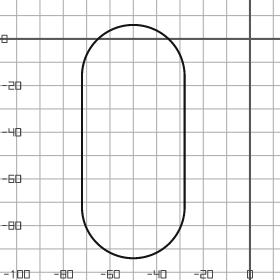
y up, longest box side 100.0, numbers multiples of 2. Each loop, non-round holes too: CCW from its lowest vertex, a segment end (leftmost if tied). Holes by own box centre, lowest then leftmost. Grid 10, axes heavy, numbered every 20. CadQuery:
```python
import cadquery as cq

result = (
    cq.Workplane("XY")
    .moveTo(-72.0, -72.0)
    .threePointArc((-50.0, -94.0), (-28.0, -72.0))
    .lineTo(-28.0, -16.0)
    .threePointArc((-50.0, 6.0), (-72.0, -16.0))
    .close()
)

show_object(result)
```